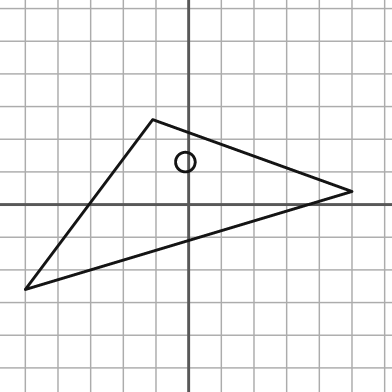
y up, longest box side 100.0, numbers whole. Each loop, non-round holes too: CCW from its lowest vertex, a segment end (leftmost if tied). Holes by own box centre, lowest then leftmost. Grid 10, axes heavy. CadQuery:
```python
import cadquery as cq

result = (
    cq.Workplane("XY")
    .moveTo(-50.0, -26.0)
    .lineTo(50.0, 4.0)
    .lineTo(-11.0, 26.0)
    .close()
    .moveTo(-1.0, 13.0)
    .circle(3.0)
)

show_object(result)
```